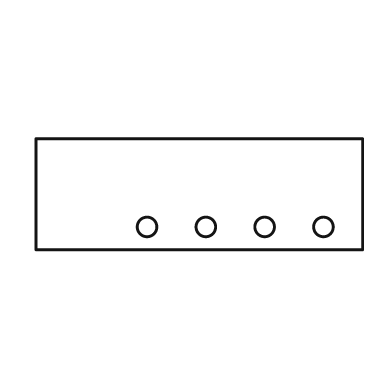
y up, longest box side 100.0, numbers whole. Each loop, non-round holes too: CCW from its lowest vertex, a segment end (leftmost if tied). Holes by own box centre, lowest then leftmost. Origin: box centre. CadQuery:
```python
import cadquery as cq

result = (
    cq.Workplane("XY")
    .moveTo(-50.0, -17.0)
    .lineTo(50.0, -17.0)
    .lineTo(50.0, 17.0)
    .lineTo(-50.0, 17.0)
    .close()
    .moveTo(-16.0, -10.0)
    .circle(3.0)
    .moveTo(2.0, -10.0)
    .circle(3.0)
    .moveTo(20.0, -10.0)
    .circle(3.0)
    .moveTo(38.0, -10.0)
    .circle(3.0)
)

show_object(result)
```